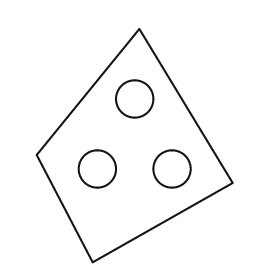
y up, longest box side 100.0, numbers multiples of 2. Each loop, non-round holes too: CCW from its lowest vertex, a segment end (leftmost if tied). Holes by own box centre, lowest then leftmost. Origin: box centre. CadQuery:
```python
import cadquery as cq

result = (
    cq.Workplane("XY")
    .moveTo(-18.0, -50.0)
    .lineTo(42.0, -16.0)
    .lineTo(2.0, 50.0)
    .lineTo(-42.0, -4.0)
    .close()
    .moveTo(-16.0, -10.0)
    .circle(8.0)
    .moveTo(16.0, -10.0)
    .circle(8.0)
    .moveTo(0.0, 20.0)
    .circle(8.0)
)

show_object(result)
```